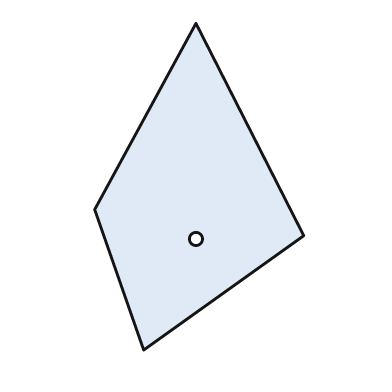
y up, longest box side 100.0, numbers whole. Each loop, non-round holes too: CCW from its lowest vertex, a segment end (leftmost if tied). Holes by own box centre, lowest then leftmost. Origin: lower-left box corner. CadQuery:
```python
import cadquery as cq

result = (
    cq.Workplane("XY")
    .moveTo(15.0, 0.0)
    .lineTo(64.0, 35.0)
    .lineTo(31.0, 100.0)
    .lineTo(0.0, 43.0)
    .close()
    .moveTo(31.0, 34.0)
    .circle(2.0)
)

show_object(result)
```